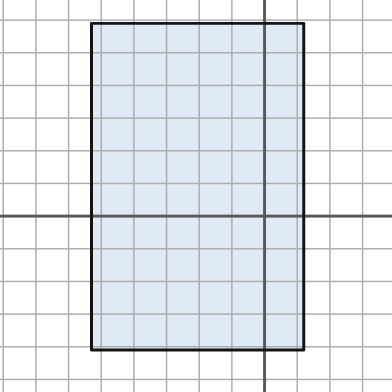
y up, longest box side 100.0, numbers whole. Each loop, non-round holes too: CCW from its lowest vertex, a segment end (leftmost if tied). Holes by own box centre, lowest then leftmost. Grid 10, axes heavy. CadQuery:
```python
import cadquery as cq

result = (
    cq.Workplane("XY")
    .moveTo(-53.0, -41.0)
    .lineTo(12.0, -41.0)
    .lineTo(12.0, 59.0)
    .lineTo(-53.0, 59.0)
    .close()
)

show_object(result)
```